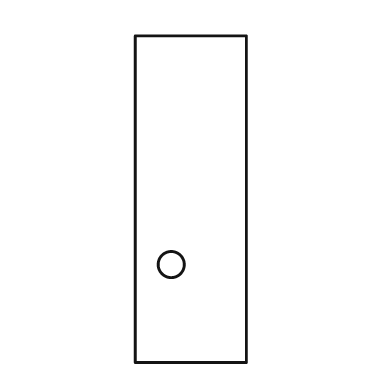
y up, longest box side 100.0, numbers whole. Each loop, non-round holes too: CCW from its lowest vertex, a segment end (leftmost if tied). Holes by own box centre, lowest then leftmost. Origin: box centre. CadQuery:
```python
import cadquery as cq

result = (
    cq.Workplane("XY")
    .moveTo(-17.0, -50.0)
    .lineTo(17.0, -50.0)
    .lineTo(17.0, 50.0)
    .lineTo(-17.0, 50.0)
    .close()
    .moveTo(-6.0, -20.0)
    .circle(4.0)
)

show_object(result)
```